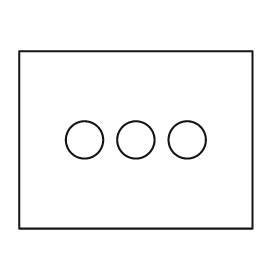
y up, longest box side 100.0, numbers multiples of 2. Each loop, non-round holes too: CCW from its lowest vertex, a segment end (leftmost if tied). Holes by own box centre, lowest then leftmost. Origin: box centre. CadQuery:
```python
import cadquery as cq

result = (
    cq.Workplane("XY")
    .moveTo(-50.0, -38.0)
    .lineTo(50.0, -38.0)
    .lineTo(50.0, 38.0)
    .lineTo(-50.0, 38.0)
    .close()
    .moveTo(-22.0, 0.0)
    .circle(8.0)
    .moveTo(0.0, 0.0)
    .circle(8.0)
    .moveTo(22.0, 0.0)
    .circle(8.0)
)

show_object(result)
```